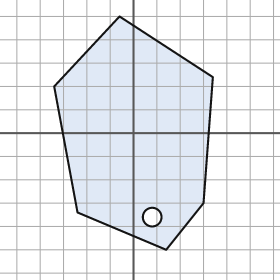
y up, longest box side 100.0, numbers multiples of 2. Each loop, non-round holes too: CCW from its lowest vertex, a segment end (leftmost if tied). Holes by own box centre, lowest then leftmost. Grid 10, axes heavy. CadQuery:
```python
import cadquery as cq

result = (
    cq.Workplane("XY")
    .moveTo(14.0, -50.0)
    .lineTo(30.0, -30.0)
    .lineTo(34.0, 24.0)
    .lineTo(-6.0, 50.0)
    .lineTo(-34.0, 20.0)
    .lineTo(-24.0, -34.0)
    .close()
    .moveTo(8.0, -36.0)
    .circle(4.0)
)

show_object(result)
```